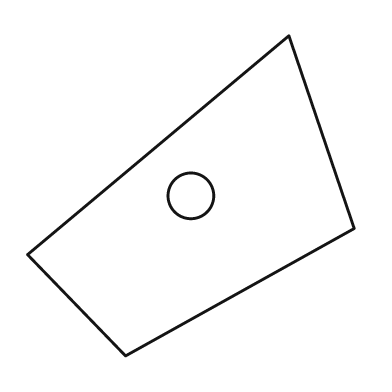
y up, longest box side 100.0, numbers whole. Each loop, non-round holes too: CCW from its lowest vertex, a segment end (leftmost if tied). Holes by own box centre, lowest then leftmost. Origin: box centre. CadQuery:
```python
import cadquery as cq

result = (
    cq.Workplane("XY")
    .moveTo(-20.0, -49.0)
    .lineTo(50.0, -10.0)
    .lineTo(30.0, 49.0)
    .lineTo(-50.0, -18.0)
    .close()
    .moveTo(0.0, 0.0)
    .circle(7.0)
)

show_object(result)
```